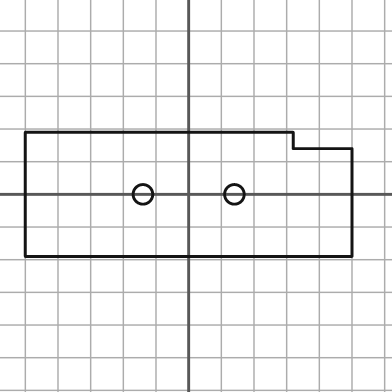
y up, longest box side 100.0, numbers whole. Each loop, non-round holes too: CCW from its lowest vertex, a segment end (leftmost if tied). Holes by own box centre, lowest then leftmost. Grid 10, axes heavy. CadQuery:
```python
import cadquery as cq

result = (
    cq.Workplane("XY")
    .moveTo(-50.0, -19.0)
    .lineTo(50.0, -19.0)
    .lineTo(50.0, 14.0)
    .lineTo(32.0, 14.0)
    .lineTo(32.0, 19.0)
    .lineTo(-50.0, 19.0)
    .close()
    .moveTo(-14.0, 0.0)
    .circle(3.0)
    .moveTo(14.0, 0.0)
    .circle(3.0)
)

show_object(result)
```